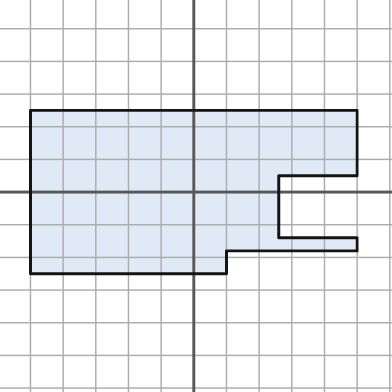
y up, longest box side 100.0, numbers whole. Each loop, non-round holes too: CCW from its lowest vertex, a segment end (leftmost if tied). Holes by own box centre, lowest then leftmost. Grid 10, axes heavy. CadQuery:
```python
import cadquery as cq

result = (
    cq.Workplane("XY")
    .moveTo(-50.0, -25.0)
    .lineTo(10.0, -25.0)
    .lineTo(10.0, -18.0)
    .lineTo(50.0, -18.0)
    .lineTo(50.0, -14.0)
    .lineTo(26.0, -14.0)
    .lineTo(26.0, 5.0)
    .lineTo(50.0, 5.0)
    .lineTo(50.0, 25.0)
    .lineTo(-50.0, 25.0)
    .close()
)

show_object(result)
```